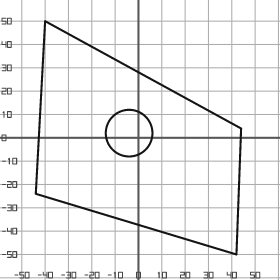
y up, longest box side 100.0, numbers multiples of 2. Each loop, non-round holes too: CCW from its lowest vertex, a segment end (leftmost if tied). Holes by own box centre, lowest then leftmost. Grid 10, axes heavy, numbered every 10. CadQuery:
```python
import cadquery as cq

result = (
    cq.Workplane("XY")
    .moveTo(42.0, -50.0)
    .lineTo(44.0, 4.0)
    .lineTo(-40.0, 50.0)
    .lineTo(-44.0, -24.0)
    .close()
    .moveTo(-4.0, 2.0)
    .circle(10.0)
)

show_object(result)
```